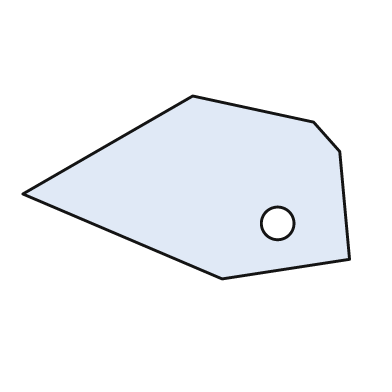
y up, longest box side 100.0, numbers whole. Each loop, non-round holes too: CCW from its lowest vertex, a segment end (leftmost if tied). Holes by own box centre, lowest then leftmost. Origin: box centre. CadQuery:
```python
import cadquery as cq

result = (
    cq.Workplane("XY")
    .moveTo(11.0, -28.0)
    .lineTo(50.0, -22.0)
    .lineTo(47.0, 11.0)
    .lineTo(39.0, 20.0)
    .lineTo(2.0, 28.0)
    .lineTo(-50.0, -2.0)
    .close()
    .moveTo(28.0, -11.0)
    .circle(5.0)
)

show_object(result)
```